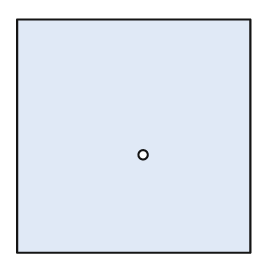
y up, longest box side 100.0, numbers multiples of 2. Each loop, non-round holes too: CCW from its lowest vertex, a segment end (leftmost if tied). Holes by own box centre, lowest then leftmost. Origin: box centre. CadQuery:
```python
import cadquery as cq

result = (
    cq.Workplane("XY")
    .moveTo(-50.0, -50.0)
    .lineTo(50.0, -50.0)
    .lineTo(50.0, 50.0)
    .lineTo(-50.0, 50.0)
    .close()
    .moveTo(4.0, -8.0)
    .circle(2.0)
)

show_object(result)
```